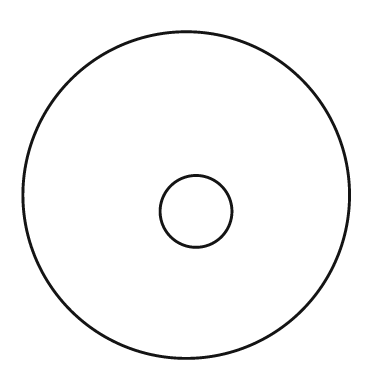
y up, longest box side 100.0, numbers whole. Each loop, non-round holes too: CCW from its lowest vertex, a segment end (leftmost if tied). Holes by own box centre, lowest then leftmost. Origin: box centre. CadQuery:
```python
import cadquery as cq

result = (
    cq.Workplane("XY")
    .moveTo(0.0, 0.0)
    .circle(50.0)
    .moveTo(3.0, -5.0)
    .circle(11.0)
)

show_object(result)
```